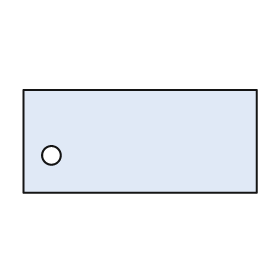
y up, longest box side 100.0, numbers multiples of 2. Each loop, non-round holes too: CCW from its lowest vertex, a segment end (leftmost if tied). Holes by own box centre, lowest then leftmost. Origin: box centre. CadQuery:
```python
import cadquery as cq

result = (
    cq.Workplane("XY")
    .moveTo(-50.0, -22.0)
    .lineTo(50.0, -22.0)
    .lineTo(50.0, 22.0)
    .lineTo(-50.0, 22.0)
    .close()
    .moveTo(-38.0, -6.0)
    .circle(4.0)
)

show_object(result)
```